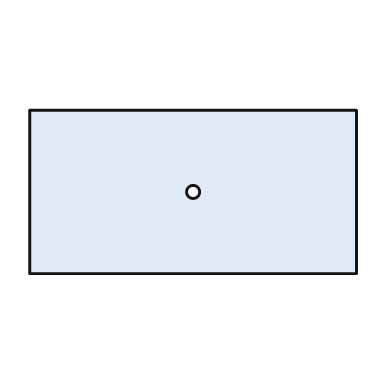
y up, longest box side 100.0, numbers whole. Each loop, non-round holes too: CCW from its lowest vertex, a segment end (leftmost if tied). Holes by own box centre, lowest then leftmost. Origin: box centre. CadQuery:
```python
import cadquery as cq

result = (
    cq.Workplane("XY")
    .moveTo(-50.0, -25.0)
    .lineTo(50.0, -25.0)
    .lineTo(50.0, 25.0)
    .lineTo(-50.0, 25.0)
    .close()
    .moveTo(0.0, 0.0)
    .circle(2.0)
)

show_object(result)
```